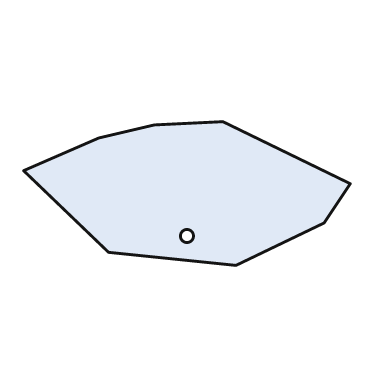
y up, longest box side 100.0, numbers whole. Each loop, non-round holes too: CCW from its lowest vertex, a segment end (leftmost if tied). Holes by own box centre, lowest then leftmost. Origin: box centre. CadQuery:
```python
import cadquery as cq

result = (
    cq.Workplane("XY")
    .moveTo(15.0, -22.0)
    .lineTo(42.0, -9.0)
    .lineTo(50.0, 3.0)
    .lineTo(11.0, 22.0)
    .lineTo(-10.0, 21.0)
    .lineTo(-27.0, 17.0)
    .lineTo(-50.0, 7.0)
    .lineTo(-24.0, -18.0)
    .close()
    .moveTo(0.0, -13.0)
    .circle(2.0)
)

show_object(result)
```